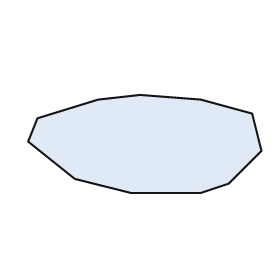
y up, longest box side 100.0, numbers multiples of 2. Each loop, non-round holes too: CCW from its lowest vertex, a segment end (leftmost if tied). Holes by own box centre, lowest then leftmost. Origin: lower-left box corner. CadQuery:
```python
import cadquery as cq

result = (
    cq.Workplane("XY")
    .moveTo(44.0, 0.0)
    .lineTo(74.0, 0.0)
    .lineTo(86.0, 4.0)
    .lineTo(100.0, 18.0)
    .lineTo(96.0, 34.0)
    .lineTo(74.0, 40.0)
    .lineTo(48.0, 42.0)
    .lineTo(30.0, 40.0)
    .lineTo(4.0, 32.0)
    .lineTo(0.0, 22.0)
    .lineTo(20.0, 6.0)
    .close()
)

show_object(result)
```